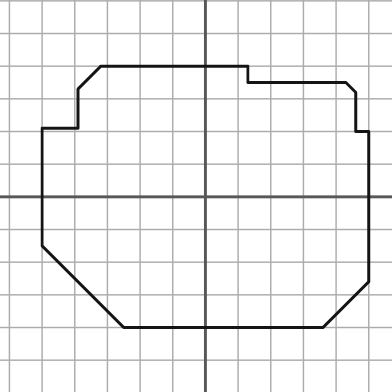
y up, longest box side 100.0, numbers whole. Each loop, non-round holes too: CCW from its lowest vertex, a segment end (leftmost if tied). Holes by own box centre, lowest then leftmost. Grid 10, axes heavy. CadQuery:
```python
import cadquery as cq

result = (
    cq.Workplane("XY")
    .moveTo(-25.0, -40.0)
    .lineTo(36.0, -40.0)
    .lineTo(50.0, -26.0)
    .lineTo(50.0, 20.0)
    .lineTo(46.0, 20.0)
    .lineTo(46.0, 32.0)
    .lineTo(43.0, 35.0)
    .lineTo(13.0, 35.0)
    .lineTo(13.0, 40.0)
    .lineTo(-32.0, 40.0)
    .lineTo(-39.0, 33.0)
    .lineTo(-39.0, 21.0)
    .lineTo(-50.0, 21.0)
    .lineTo(-50.0, -15.0)
    .close()
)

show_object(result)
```